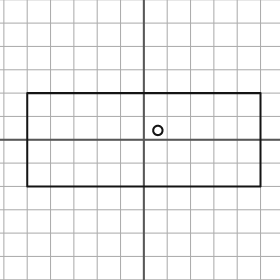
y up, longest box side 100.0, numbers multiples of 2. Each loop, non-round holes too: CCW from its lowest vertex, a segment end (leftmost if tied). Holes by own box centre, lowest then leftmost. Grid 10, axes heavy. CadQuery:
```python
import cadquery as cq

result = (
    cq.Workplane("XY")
    .moveTo(-50.0, -20.0)
    .lineTo(50.0, -20.0)
    .lineTo(50.0, 20.0)
    .lineTo(-50.0, 20.0)
    .close()
    .moveTo(6.0, 4.0)
    .circle(2.0)
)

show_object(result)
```